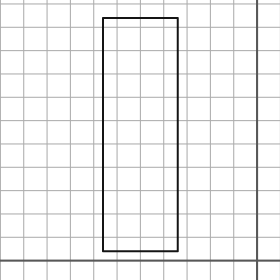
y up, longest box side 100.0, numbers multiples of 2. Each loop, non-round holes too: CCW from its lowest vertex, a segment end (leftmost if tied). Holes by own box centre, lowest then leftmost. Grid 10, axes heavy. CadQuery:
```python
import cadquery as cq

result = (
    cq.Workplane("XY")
    .moveTo(-66.0, 4.0)
    .lineTo(-34.0, 4.0)
    .lineTo(-34.0, 104.0)
    .lineTo(-66.0, 104.0)
    .close()
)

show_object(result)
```